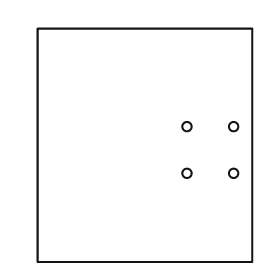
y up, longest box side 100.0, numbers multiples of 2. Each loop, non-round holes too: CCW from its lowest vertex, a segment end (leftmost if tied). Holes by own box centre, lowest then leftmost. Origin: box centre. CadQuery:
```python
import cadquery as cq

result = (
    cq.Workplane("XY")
    .moveTo(-46.0, -50.0)
    .lineTo(46.0, -50.0)
    .lineTo(46.0, 50.0)
    .lineTo(-46.0, 50.0)
    .close()
    .moveTo(18.0, -12.0)
    .circle(2.0)
    .moveTo(38.0, -12.0)
    .circle(2.0)
    .moveTo(18.0, 8.0)
    .circle(2.0)
    .moveTo(38.0, 8.0)
    .circle(2.0)
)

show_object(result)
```